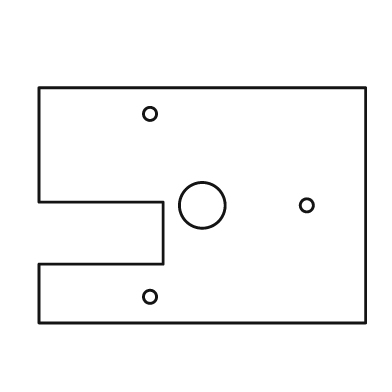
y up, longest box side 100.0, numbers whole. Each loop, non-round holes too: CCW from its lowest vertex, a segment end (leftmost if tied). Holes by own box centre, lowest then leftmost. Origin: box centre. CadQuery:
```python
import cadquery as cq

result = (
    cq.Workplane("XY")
    .moveTo(-50.0, -36.0)
    .lineTo(50.0, -36.0)
    .lineTo(50.0, 36.0)
    .lineTo(-50.0, 36.0)
    .lineTo(-50.0, 1.0)
    .lineTo(-12.0, 1.0)
    .lineTo(-12.0, -18.0)
    .lineTo(-50.0, -18.0)
    .close()
    .moveTo(-16.0, -28.0)
    .circle(2.0)
    .moveTo(0.0, 0.0)
    .circle(7.0)
    .moveTo(32.0, 0.0)
    .circle(2.0)
    .moveTo(-16.0, 28.0)
    .circle(2.0)
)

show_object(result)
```